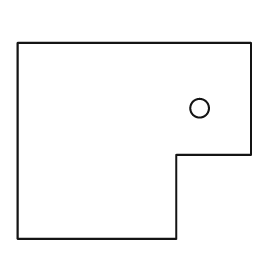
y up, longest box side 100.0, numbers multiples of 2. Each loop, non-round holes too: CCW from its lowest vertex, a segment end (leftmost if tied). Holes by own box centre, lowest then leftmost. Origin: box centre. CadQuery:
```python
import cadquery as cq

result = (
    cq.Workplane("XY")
    .moveTo(-50.0, -42.0)
    .lineTo(18.0, -42.0)
    .lineTo(18.0, -6.0)
    .lineTo(50.0, -6.0)
    .lineTo(50.0, 42.0)
    .lineTo(-50.0, 42.0)
    .close()
    .moveTo(28.0, 14.0)
    .circle(4.0)
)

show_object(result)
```